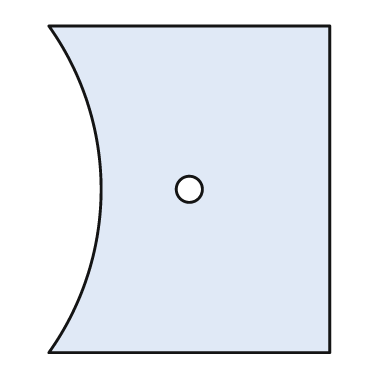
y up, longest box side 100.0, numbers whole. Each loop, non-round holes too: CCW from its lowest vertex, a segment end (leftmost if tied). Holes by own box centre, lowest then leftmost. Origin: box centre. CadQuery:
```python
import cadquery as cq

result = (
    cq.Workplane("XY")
    .moveTo(-43.0, -50.0)
    .lineTo(43.0, -50.0)
    .lineTo(43.0, 50.0)
    .lineTo(-43.0, 50.0)
    .threePointArc((-27.0, 0.0), (-43.0, -50.0))
    .close()
    .moveTo(0.0, 0.0)
    .circle(4.0)
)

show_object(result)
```